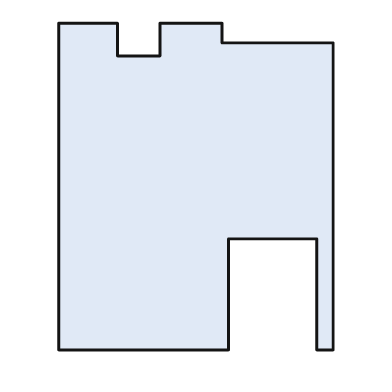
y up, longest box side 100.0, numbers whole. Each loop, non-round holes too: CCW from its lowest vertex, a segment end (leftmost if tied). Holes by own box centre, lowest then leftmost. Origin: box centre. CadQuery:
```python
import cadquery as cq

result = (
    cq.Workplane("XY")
    .moveTo(-42.0, -50.0)
    .lineTo(10.0, -50.0)
    .lineTo(10.0, -16.0)
    .lineTo(37.0, -16.0)
    .lineTo(37.0, -50.0)
    .lineTo(42.0, -50.0)
    .lineTo(42.0, 44.0)
    .lineTo(8.0, 44.0)
    .lineTo(8.0, 50.0)
    .lineTo(-11.0, 50.0)
    .lineTo(-11.0, 40.0)
    .lineTo(-24.0, 40.0)
    .lineTo(-24.0, 50.0)
    .lineTo(-42.0, 50.0)
    .close()
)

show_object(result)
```